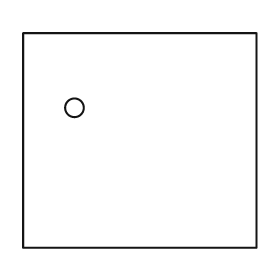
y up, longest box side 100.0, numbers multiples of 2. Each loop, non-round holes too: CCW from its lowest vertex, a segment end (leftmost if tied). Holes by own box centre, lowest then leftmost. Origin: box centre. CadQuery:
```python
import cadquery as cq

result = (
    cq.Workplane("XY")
    .moveTo(-50.0, -46.0)
    .lineTo(50.0, -46.0)
    .lineTo(50.0, 46.0)
    .lineTo(-50.0, 46.0)
    .close()
    .moveTo(-28.0, 14.0)
    .circle(4.0)
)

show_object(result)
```